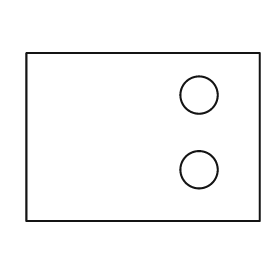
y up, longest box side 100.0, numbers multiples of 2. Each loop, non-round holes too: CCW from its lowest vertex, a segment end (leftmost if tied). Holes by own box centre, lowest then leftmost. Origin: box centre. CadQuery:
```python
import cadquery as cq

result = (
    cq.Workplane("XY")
    .moveTo(-50.0, -36.0)
    .lineTo(50.0, -36.0)
    .lineTo(50.0, 36.0)
    .lineTo(-50.0, 36.0)
    .close()
    .moveTo(24.0, -14.0)
    .circle(8.0)
    .moveTo(24.0, 18.0)
    .circle(8.0)
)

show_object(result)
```